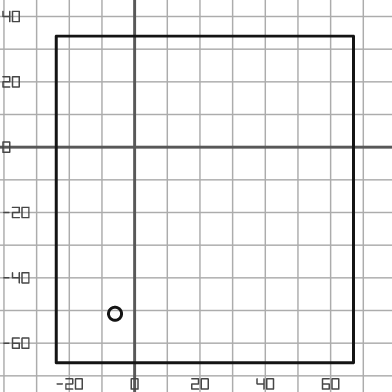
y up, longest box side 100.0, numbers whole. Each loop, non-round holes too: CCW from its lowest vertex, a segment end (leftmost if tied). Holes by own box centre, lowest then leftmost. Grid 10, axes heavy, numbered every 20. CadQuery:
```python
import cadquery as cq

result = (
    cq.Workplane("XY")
    .moveTo(-24.0, -66.0)
    .lineTo(67.0, -66.0)
    .lineTo(67.0, 34.0)
    .lineTo(-24.0, 34.0)
    .close()
    .moveTo(-6.0, -51.0)
    .circle(2.0)
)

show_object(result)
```